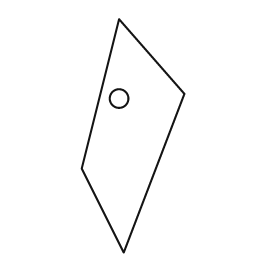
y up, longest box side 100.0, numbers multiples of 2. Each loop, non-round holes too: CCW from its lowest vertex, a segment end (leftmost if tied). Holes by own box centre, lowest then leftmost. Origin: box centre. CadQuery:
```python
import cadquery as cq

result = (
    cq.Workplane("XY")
    .moveTo(-4.0, -50.0)
    .lineTo(22.0, 18.0)
    .lineTo(-6.0, 50.0)
    .lineTo(-22.0, -14.0)
    .close()
    .moveTo(-6.0, 16.0)
    .circle(4.0)
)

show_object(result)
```